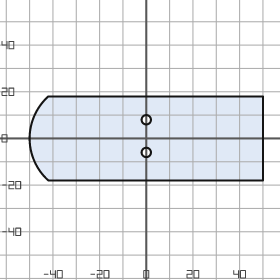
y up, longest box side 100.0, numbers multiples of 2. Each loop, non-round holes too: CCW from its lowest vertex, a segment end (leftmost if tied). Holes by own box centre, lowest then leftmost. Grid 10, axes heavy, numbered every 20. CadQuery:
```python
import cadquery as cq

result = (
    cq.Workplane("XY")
    .moveTo(-42.0, -18.0)
    .lineTo(50.0, -18.0)
    .lineTo(50.0, 18.0)
    .lineTo(-42.0, 18.0)
    .threePointArc((-50.0, 0.0), (-42.0, -18.0))
    .close()
    .moveTo(0.0, -6.0)
    .circle(2.0)
    .moveTo(0.0, 8.0)
    .circle(2.0)
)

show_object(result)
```